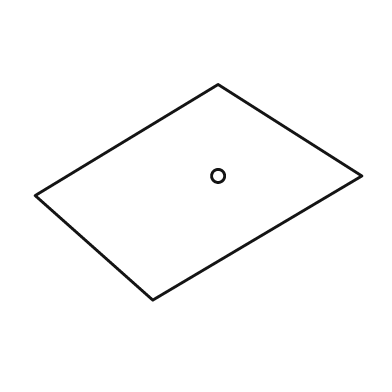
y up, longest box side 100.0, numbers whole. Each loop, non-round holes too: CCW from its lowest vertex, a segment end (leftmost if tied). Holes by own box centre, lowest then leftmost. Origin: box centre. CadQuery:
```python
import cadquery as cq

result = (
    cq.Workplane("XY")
    .moveTo(-14.0, -33.0)
    .lineTo(50.0, 5.0)
    .lineTo(6.0, 33.0)
    .lineTo(-50.0, -1.0)
    .close()
    .moveTo(6.0, 5.0)
    .circle(2.0)
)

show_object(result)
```